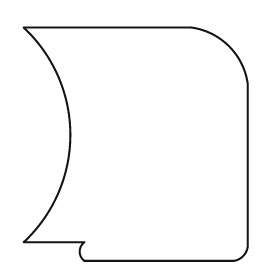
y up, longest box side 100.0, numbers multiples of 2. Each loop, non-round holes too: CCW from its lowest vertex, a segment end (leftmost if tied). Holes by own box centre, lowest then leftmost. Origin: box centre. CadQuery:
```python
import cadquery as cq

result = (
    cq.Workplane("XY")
    .moveTo(-22.0, -50.0)
    .lineTo(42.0, -50.0)
    .threePointArc((46.0, -48.0), (48.0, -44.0))
    .lineTo(48.0, 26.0)
    .threePointArc((40.0, 42.0), (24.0, 50.0))
    .lineTo(-48.0, 50.0)
    .threePointArc((-28.0, 4.0), (-48.0, -42.0))
    .lineTo(-22.0, -42.0)
    .threePointArc((-24.0, -46.0), (-22.0, -50.0))
    .close()
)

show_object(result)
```